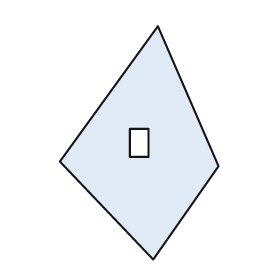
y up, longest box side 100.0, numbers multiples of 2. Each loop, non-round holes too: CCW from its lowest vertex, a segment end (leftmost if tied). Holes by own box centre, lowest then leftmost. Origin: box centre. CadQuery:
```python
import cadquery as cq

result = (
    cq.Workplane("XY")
    .moveTo(6.0, -50.0)
    .lineTo(34.0, -10.0)
    .lineTo(8.0, 50.0)
    .lineTo(-34.0, -8.0)
    .close()
    .moveTo(-4.0, -6.0)
    .lineTo(4.0, -6.0)
    .lineTo(4.0, 6.0)
    .lineTo(-4.0, 6.0)
    .close()
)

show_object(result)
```